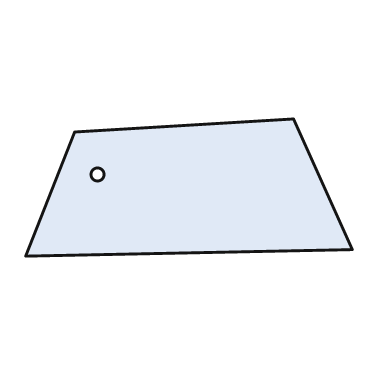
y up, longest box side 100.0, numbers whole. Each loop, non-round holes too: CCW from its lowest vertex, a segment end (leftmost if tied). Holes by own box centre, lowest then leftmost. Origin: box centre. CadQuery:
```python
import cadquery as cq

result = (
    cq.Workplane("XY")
    .moveTo(-50.0, -21.0)
    .lineTo(50.0, -19.0)
    .lineTo(32.0, 21.0)
    .lineTo(-35.0, 17.0)
    .close()
    .moveTo(-28.0, 4.0)
    .circle(2.0)
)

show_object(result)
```